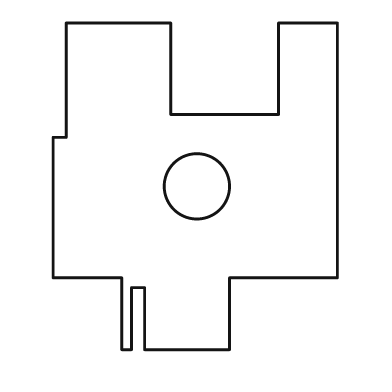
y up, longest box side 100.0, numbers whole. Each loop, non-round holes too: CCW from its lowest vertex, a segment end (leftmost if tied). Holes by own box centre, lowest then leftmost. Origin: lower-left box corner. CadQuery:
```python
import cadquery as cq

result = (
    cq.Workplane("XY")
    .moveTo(21.0, 0.0)
    .lineTo(24.0, 0.0)
    .lineTo(24.0, 19.0)
    .lineTo(28.0, 19.0)
    .lineTo(28.0, 0.0)
    .lineTo(54.0, 0.0)
    .lineTo(54.0, 22.0)
    .lineTo(87.0, 22.0)
    .lineTo(87.0, 100.0)
    .lineTo(69.0, 100.0)
    .lineTo(69.0, 72.0)
    .lineTo(36.0, 72.0)
    .lineTo(36.0, 100.0)
    .lineTo(4.0, 100.0)
    .lineTo(4.0, 65.0)
    .lineTo(0.0, 65.0)
    .lineTo(0.0, 22.0)
    .lineTo(21.0, 22.0)
    .close()
    .moveTo(44.0, 50.0)
    .circle(10.0)
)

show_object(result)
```